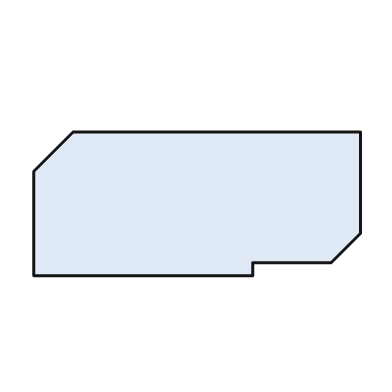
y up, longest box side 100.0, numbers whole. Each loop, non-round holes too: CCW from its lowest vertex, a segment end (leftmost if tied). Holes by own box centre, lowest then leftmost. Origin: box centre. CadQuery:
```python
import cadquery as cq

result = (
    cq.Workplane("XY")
    .moveTo(-50.0, -22.0)
    .lineTo(17.0, -22.0)
    .lineTo(17.0, -18.0)
    .lineTo(41.0, -18.0)
    .lineTo(50.0, -9.0)
    .lineTo(50.0, 22.0)
    .lineTo(-38.0, 22.0)
    .lineTo(-50.0, 10.0)
    .close()
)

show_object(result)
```